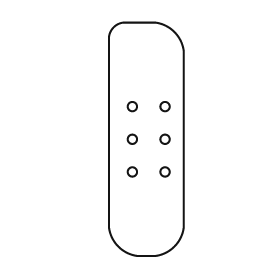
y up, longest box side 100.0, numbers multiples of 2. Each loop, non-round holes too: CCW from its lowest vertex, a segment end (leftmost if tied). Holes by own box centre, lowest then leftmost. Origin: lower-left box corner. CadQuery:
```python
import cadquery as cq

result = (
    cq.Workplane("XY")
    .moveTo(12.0, 0.0)
    .lineTo(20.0, 0.0)
    .threePointArc((28.0, 4.0), (32.0, 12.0))
    .lineTo(32.0, 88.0)
    .threePointArc((28.0, 96.0), (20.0, 100.0))
    .lineTo(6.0, 100.0)
    .threePointArc((2.0, 98.0), (0.0, 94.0))
    .lineTo(0.0, 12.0)
    .threePointArc((4.0, 4.0), (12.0, 0.0))
    .close()
    .moveTo(10.0, 36.0)
    .circle(2.0)
    .moveTo(24.0, 36.0)
    .circle(2.0)
    .moveTo(10.0, 50.0)
    .circle(2.0)
    .moveTo(24.0, 50.0)
    .circle(2.0)
    .moveTo(10.0, 64.0)
    .circle(2.0)
    .moveTo(24.0, 64.0)
    .circle(2.0)
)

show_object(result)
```